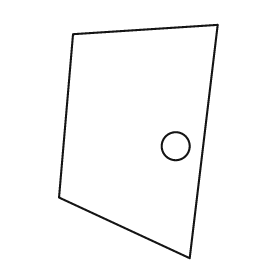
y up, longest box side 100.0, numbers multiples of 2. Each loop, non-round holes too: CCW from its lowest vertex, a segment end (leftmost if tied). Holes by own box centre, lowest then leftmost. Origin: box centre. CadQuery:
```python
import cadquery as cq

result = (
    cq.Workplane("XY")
    .moveTo(22.0, -50.0)
    .lineTo(34.0, 50.0)
    .lineTo(-28.0, 46.0)
    .lineTo(-34.0, -24.0)
    .close()
    .moveTo(16.0, -2.0)
    .circle(6.0)
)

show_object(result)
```